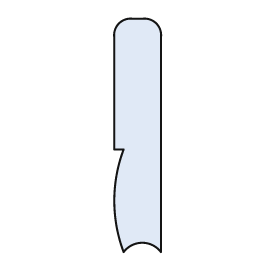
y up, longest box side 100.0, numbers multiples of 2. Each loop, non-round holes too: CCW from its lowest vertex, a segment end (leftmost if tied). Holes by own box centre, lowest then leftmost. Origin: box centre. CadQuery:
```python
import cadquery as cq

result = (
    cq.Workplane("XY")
    .moveTo(-6.0, -50.0)
    .threePointArc((2.0, -46.0), (10.0, -50.0))
    .lineTo(10.0, 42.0)
    .threePointArc((8.0, 48.0), (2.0, 50.0))
    .lineTo(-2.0, 50.0)
    .threePointArc((-8.0, 48.0), (-10.0, 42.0))
    .lineTo(-10.0, -6.0)
    .lineTo(-6.0, -6.0)
    .threePointArc((-10.0, -28.0), (-6.0, -50.0))
    .close()
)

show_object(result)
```